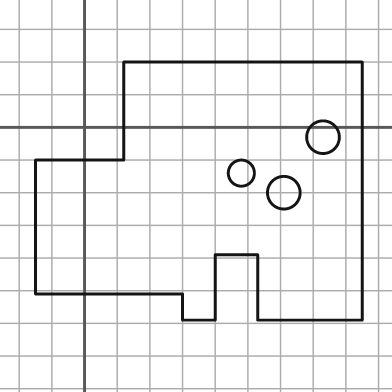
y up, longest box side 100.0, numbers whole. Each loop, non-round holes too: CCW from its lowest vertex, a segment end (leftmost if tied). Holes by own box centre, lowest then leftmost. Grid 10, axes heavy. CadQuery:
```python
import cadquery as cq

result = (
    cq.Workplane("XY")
    .moveTo(30.0, -59.0)
    .lineTo(40.0, -59.0)
    .lineTo(40.0, -39.0)
    .lineTo(53.0, -39.0)
    .lineTo(53.0, -59.0)
    .lineTo(85.0, -59.0)
    .lineTo(85.0, 20.0)
    .lineTo(12.0, 20.0)
    .lineTo(12.0, -10.0)
    .lineTo(-15.0, -10.0)
    .lineTo(-15.0, -51.0)
    .lineTo(30.0, -51.0)
    .close()
    .moveTo(61.0, -20.0)
    .circle(5.0)
    .moveTo(48.0, -14.0)
    .circle(4.0)
    .moveTo(73.0, -3.0)
    .circle(5.0)
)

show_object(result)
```